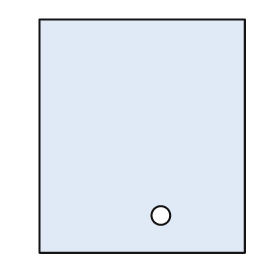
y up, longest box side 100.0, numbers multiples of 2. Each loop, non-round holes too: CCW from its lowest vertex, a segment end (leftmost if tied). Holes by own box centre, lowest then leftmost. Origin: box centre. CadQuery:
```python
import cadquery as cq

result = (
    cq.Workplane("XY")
    .moveTo(-44.0, -50.0)
    .lineTo(44.0, -50.0)
    .lineTo(44.0, 50.0)
    .lineTo(-44.0, 50.0)
    .close()
    .moveTo(8.0, -34.0)
    .circle(4.0)
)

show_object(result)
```